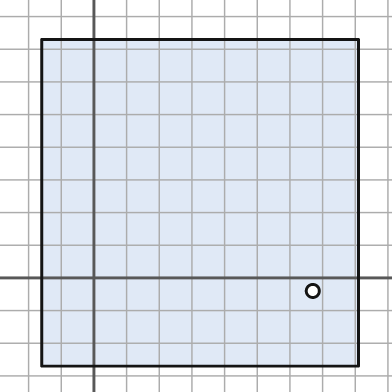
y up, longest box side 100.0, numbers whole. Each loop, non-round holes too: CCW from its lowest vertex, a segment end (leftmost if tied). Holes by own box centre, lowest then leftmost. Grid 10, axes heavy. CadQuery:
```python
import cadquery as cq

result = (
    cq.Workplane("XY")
    .moveTo(-16.0, -27.0)
    .lineTo(81.0, -27.0)
    .lineTo(81.0, 73.0)
    .lineTo(-16.0, 73.0)
    .close()
    .moveTo(67.0, -4.0)
    .circle(2.0)
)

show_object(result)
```